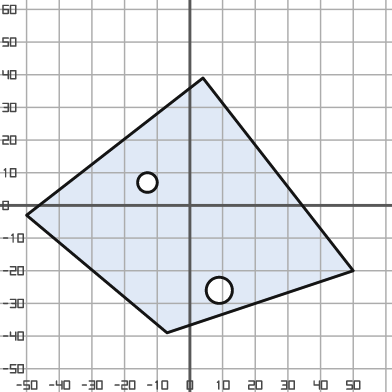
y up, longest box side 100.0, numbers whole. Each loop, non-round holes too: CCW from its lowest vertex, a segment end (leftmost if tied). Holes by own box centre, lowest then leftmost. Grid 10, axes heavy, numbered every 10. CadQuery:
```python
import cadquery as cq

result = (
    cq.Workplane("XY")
    .moveTo(-7.0, -39.0)
    .lineTo(50.0, -20.0)
    .lineTo(4.0, 39.0)
    .lineTo(-50.0, -3.0)
    .close()
    .moveTo(9.0, -26.0)
    .circle(4.0)
    .moveTo(-13.0, 7.0)
    .circle(3.0)
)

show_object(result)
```